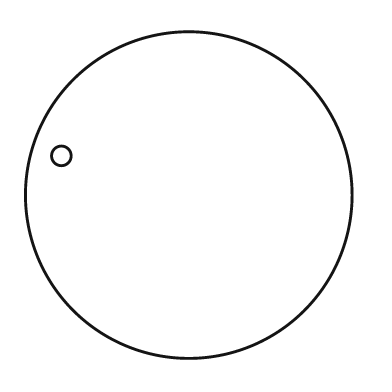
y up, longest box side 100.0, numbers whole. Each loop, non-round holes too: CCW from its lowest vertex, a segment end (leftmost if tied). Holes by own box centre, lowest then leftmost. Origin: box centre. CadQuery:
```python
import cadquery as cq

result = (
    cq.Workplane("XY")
    .moveTo(0.0, 0.0)
    .circle(50.0)
    .moveTo(-39.0, 12.0)
    .circle(3.0)
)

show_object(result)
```